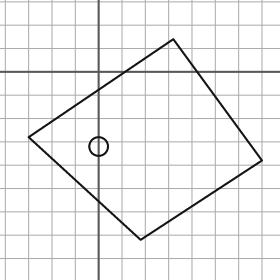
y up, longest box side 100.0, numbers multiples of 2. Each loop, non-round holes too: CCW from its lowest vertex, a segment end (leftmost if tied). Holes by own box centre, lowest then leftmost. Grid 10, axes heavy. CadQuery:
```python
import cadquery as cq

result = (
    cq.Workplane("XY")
    .moveTo(18.0, -72.0)
    .lineTo(70.0, -38.0)
    .lineTo(32.0, 14.0)
    .lineTo(-30.0, -28.0)
    .close()
    .moveTo(0.0, -32.0)
    .circle(4.0)
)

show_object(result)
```